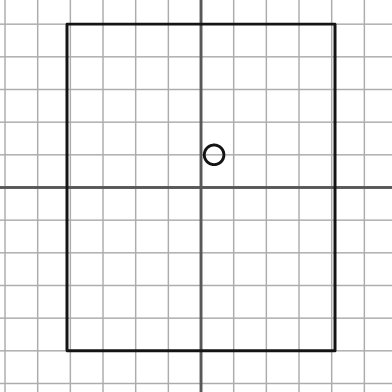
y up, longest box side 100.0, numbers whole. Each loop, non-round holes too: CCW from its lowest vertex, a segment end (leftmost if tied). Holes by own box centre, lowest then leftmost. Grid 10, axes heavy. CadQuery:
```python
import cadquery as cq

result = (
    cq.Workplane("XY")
    .moveTo(-41.0, -50.0)
    .lineTo(41.0, -50.0)
    .lineTo(41.0, 50.0)
    .lineTo(-41.0, 50.0)
    .close()
    .moveTo(4.0, 10.0)
    .circle(3.0)
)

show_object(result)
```